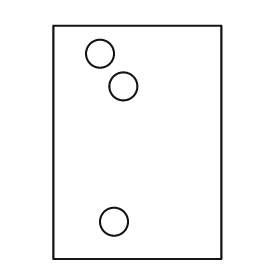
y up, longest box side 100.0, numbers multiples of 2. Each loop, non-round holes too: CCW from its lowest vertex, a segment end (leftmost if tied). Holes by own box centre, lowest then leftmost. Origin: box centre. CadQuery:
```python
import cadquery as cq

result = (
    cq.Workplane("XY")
    .moveTo(-36.0, -50.0)
    .lineTo(36.0, -50.0)
    .lineTo(36.0, 50.0)
    .lineTo(-36.0, 50.0)
    .close()
    .moveTo(-10.0, -34.0)
    .circle(6.0)
    .moveTo(-6.0, 24.0)
    .circle(6.0)
    .moveTo(-16.0, 38.0)
    .circle(6.0)
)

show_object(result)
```